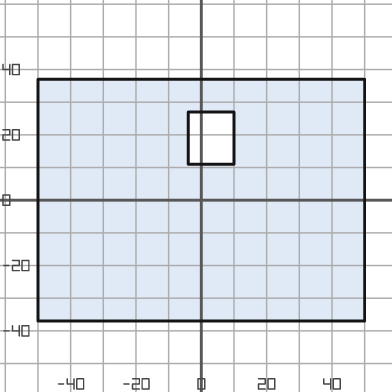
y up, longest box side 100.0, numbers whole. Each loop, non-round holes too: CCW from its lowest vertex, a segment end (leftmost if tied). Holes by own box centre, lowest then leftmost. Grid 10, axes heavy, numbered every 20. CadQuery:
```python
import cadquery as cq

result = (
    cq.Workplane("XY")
    .moveTo(-50.0, -37.0)
    .lineTo(50.0, -37.0)
    .lineTo(50.0, 37.0)
    .lineTo(-50.0, 37.0)
    .close()
    .moveTo(-4.0, 11.0)
    .lineTo(10.0, 11.0)
    .lineTo(10.0, 27.0)
    .lineTo(-4.0, 27.0)
    .close()
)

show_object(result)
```